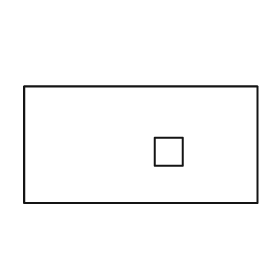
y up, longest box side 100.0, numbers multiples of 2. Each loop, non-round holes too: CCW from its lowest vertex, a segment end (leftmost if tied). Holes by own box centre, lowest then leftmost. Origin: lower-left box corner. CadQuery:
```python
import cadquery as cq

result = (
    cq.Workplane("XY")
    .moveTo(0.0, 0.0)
    .lineTo(100.0, 0.0)
    .lineTo(100.0, 50.0)
    .lineTo(0.0, 50.0)
    .close()
    .moveTo(56.0, 16.0)
    .lineTo(68.0, 16.0)
    .lineTo(68.0, 28.0)
    .lineTo(56.0, 28.0)
    .close()
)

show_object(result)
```